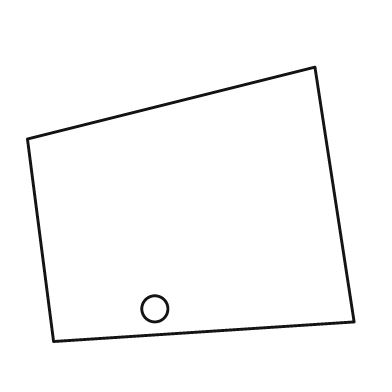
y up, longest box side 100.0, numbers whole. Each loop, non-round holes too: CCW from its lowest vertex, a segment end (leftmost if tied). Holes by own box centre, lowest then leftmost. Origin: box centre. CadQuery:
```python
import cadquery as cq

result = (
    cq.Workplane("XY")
    .moveTo(-42.0, -42.0)
    .lineTo(50.0, -36.0)
    .lineTo(38.0, 42.0)
    .lineTo(-50.0, 20.0)
    .close()
    .moveTo(-11.0, -32.0)
    .circle(4.0)
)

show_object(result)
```